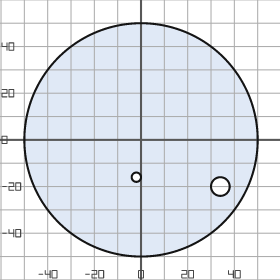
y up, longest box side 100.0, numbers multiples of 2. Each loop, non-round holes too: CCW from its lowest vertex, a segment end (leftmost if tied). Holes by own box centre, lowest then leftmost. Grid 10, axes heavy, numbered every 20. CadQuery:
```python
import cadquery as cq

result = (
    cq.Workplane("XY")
    .moveTo(0.0, 0.0)
    .circle(50.0)
    .moveTo(34.0, -20.0)
    .circle(4.0)
    .moveTo(-2.0, -16.0)
    .circle(2.0)
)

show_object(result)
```